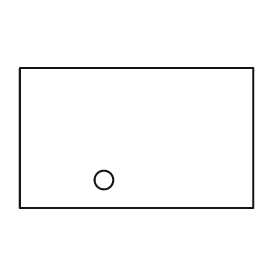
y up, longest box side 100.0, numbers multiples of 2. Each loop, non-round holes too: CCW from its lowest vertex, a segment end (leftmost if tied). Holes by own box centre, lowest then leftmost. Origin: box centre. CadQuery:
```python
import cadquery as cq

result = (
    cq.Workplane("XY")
    .moveTo(-50.0, -30.0)
    .lineTo(50.0, -30.0)
    .lineTo(50.0, 30.0)
    .lineTo(-50.0, 30.0)
    .close()
    .moveTo(-14.0, -18.0)
    .circle(4.0)
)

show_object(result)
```